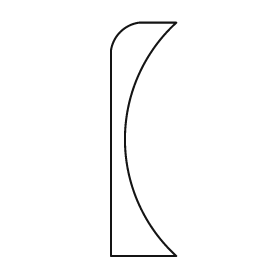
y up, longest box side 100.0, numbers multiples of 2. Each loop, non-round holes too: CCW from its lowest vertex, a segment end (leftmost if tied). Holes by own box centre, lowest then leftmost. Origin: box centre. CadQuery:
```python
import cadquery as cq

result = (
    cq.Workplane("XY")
    .moveTo(-14.0, -50.0)
    .lineTo(14.0, -50.0)
    .threePointArc((-8.0, 0.0), (14.0, 50.0))
    .lineTo(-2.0, 50.0)
    .threePointArc((-10.0, 46.0), (-14.0, 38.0))
    .close()
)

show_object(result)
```